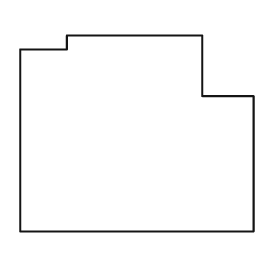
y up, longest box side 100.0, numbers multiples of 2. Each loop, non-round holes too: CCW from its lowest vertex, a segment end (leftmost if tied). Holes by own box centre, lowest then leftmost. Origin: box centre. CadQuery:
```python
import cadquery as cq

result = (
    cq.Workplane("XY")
    .moveTo(-50.0, -42.0)
    .lineTo(50.0, -42.0)
    .lineTo(50.0, 16.0)
    .lineTo(28.0, 16.0)
    .lineTo(28.0, 42.0)
    .lineTo(-30.0, 42.0)
    .lineTo(-30.0, 36.0)
    .lineTo(-50.0, 36.0)
    .close()
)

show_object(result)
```